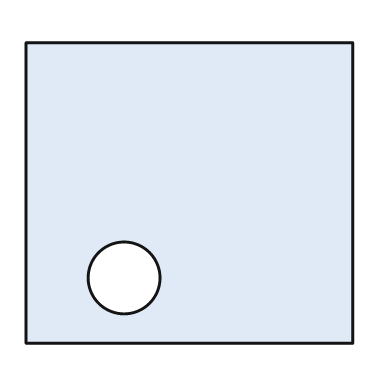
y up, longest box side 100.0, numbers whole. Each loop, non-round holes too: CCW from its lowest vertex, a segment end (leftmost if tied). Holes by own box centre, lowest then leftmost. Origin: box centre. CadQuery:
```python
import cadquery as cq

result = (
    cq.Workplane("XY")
    .moveTo(-50.0, -46.0)
    .lineTo(50.0, -46.0)
    .lineTo(50.0, 46.0)
    .lineTo(-50.0, 46.0)
    .close()
    .moveTo(-20.0, -26.0)
    .circle(11.0)
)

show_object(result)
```